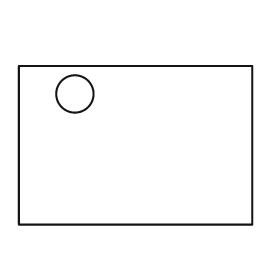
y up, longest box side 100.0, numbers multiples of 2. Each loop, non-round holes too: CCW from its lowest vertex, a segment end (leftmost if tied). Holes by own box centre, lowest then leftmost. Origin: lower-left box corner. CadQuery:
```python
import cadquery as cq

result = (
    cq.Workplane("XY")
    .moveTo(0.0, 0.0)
    .lineTo(100.0, 0.0)
    .lineTo(100.0, 68.0)
    .lineTo(0.0, 68.0)
    .close()
    .moveTo(24.0, 56.0)
    .circle(8.0)
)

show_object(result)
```